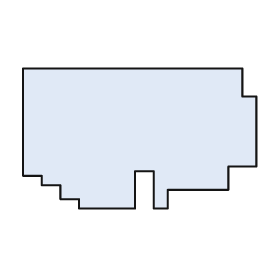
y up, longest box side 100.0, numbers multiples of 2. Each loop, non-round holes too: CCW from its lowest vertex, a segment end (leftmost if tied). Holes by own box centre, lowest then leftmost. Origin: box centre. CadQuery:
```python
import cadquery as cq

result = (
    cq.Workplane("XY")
    .moveTo(-26.0, -30.0)
    .lineTo(-2.0, -30.0)
    .lineTo(-2.0, -14.0)
    .lineTo(6.0, -14.0)
    .lineTo(6.0, -30.0)
    .lineTo(12.0, -30.0)
    .lineTo(12.0, -22.0)
    .lineTo(38.0, -22.0)
    .lineTo(38.0, -12.0)
    .lineTo(50.0, -12.0)
    .lineTo(50.0, 18.0)
    .lineTo(44.0, 18.0)
    .lineTo(44.0, 30.0)
    .lineTo(-50.0, 30.0)
    .lineTo(-50.0, -16.0)
    .lineTo(-42.0, -16.0)
    .lineTo(-42.0, -20.0)
    .lineTo(-34.0, -20.0)
    .lineTo(-34.0, -26.0)
    .lineTo(-26.0, -26.0)
    .close()
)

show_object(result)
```